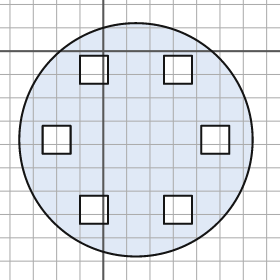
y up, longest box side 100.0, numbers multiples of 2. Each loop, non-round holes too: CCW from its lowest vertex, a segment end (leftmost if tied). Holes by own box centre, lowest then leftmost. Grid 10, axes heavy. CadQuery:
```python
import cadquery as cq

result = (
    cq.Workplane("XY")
    .moveTo(14.0, -38.0)
    .circle(50.0)
    .moveTo(-10.0, -74.0)
    .lineTo(2.0, -74.0)
    .lineTo(2.0, -62.0)
    .lineTo(-10.0, -62.0)
    .close()
    .moveTo(26.0, -74.0)
    .lineTo(38.0, -74.0)
    .lineTo(38.0, -62.0)
    .lineTo(26.0, -62.0)
    .close()
    .moveTo(-26.0, -44.0)
    .lineTo(-14.0, -44.0)
    .lineTo(-14.0, -32.0)
    .lineTo(-26.0, -32.0)
    .close()
    .moveTo(42.0, -44.0)
    .lineTo(54.0, -44.0)
    .lineTo(54.0, -32.0)
    .lineTo(42.0, -32.0)
    .close()
    .moveTo(-10.0, -14.0)
    .lineTo(2.0, -14.0)
    .lineTo(2.0, -2.0)
    .lineTo(-10.0, -2.0)
    .close()
    .moveTo(26.0, -14.0)
    .lineTo(38.0, -14.0)
    .lineTo(38.0, -2.0)
    .lineTo(26.0, -2.0)
    .close()
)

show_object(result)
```